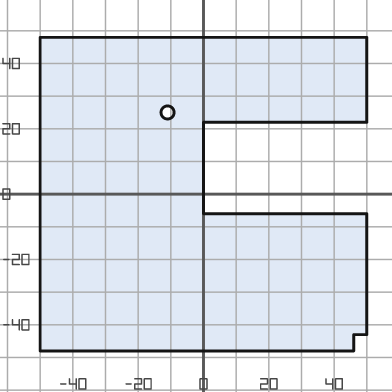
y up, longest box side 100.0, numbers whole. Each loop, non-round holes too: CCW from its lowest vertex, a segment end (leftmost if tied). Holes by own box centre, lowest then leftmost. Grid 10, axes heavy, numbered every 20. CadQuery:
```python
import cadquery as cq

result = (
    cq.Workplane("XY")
    .moveTo(-50.0, -48.0)
    .lineTo(46.0, -48.0)
    .lineTo(46.0, -43.0)
    .lineTo(50.0, -43.0)
    .lineTo(50.0, -6.0)
    .lineTo(0.0, -6.0)
    .lineTo(0.0, 22.0)
    .lineTo(50.0, 22.0)
    .lineTo(50.0, 48.0)
    .lineTo(-50.0, 48.0)
    .close()
    .moveTo(-11.0, 25.0)
    .circle(2.0)
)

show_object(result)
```